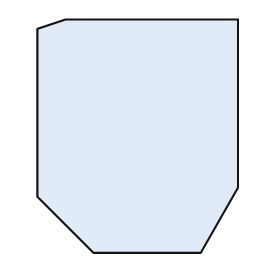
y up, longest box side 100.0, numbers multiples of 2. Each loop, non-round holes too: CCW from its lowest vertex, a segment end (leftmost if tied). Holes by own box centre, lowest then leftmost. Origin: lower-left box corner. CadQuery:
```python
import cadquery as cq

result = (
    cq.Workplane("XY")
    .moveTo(24.0, 0.0)
    .lineTo(70.0, 0.0)
    .lineTo(86.0, 28.0)
    .lineTo(86.0, 100.0)
    .lineTo(12.0, 100.0)
    .lineTo(0.0, 96.0)
    .lineTo(0.0, 24.0)
    .close()
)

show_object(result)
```